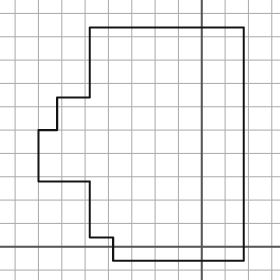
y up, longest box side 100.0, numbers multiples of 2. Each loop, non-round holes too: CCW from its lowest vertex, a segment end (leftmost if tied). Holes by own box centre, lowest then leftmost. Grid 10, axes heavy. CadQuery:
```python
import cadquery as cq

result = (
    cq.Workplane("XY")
    .moveTo(-38.0, -6.0)
    .lineTo(18.0, -6.0)
    .lineTo(18.0, 94.0)
    .lineTo(-48.0, 94.0)
    .lineTo(-48.0, 64.0)
    .lineTo(-62.0, 64.0)
    .lineTo(-62.0, 50.0)
    .lineTo(-70.0, 50.0)
    .lineTo(-70.0, 28.0)
    .lineTo(-48.0, 28.0)
    .lineTo(-48.0, 4.0)
    .lineTo(-38.0, 4.0)
    .close()
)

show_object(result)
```